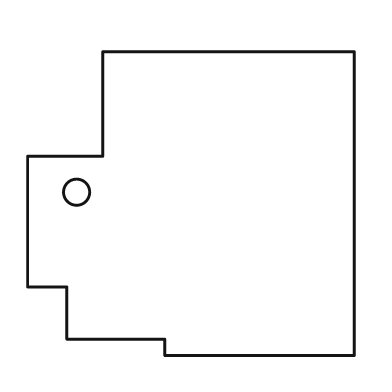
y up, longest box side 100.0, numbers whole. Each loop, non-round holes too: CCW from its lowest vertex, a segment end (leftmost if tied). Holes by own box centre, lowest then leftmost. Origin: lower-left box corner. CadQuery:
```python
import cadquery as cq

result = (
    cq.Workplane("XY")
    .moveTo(42.0, 0.0)
    .lineTo(100.0, 0.0)
    .lineTo(100.0, 93.0)
    .lineTo(23.0, 93.0)
    .lineTo(23.0, 61.0)
    .lineTo(0.0, 61.0)
    .lineTo(0.0, 21.0)
    .lineTo(12.0, 21.0)
    .lineTo(12.0, 5.0)
    .lineTo(42.0, 5.0)
    .close()
    .moveTo(15.0, 50.0)
    .circle(4.0)
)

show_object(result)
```